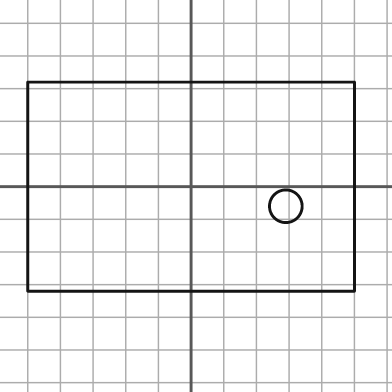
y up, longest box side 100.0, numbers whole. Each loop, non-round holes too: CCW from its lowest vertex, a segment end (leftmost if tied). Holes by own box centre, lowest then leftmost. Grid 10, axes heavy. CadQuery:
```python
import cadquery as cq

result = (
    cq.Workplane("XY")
    .moveTo(-50.0, -32.0)
    .lineTo(50.0, -32.0)
    .lineTo(50.0, 32.0)
    .lineTo(-50.0, 32.0)
    .close()
    .moveTo(29.0, -6.0)
    .circle(5.0)
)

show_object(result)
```